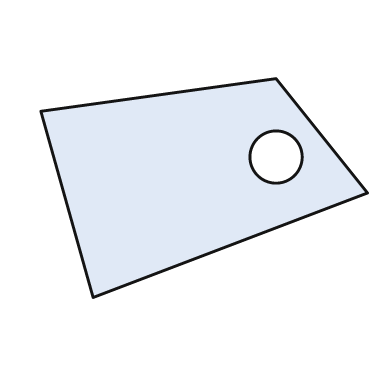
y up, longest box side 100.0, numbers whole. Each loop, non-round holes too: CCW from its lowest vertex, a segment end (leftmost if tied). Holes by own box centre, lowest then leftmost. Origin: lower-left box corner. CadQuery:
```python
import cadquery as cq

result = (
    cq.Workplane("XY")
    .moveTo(16.0, 0.0)
    .lineTo(100.0, 32.0)
    .lineTo(72.0, 67.0)
    .lineTo(0.0, 57.0)
    .close()
    .moveTo(72.0, 43.0)
    .circle(8.0)
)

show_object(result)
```